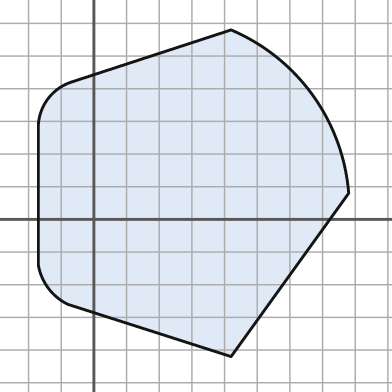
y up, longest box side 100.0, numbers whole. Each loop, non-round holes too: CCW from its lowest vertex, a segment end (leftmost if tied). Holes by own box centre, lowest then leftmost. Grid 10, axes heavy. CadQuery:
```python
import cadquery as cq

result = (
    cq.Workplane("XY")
    .moveTo(42.0, -42.0)
    .lineTo(78.0, 8.0)
    .threePointArc((67.0, 38.0), (42.0, 58.0))
    .lineTo(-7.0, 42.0)
    .threePointArc((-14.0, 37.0), (-17.0, 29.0))
    .lineTo(-17.0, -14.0)
    .threePointArc((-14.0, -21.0), (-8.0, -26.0))
    .close()
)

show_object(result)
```